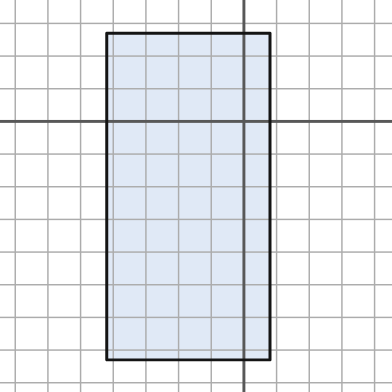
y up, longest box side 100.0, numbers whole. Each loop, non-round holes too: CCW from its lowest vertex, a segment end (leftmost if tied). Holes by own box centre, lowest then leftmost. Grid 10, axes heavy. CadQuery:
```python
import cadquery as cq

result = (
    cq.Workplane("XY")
    .moveTo(-42.0, -73.0)
    .lineTo(8.0, -73.0)
    .lineTo(8.0, 27.0)
    .lineTo(-42.0, 27.0)
    .close()
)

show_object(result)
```